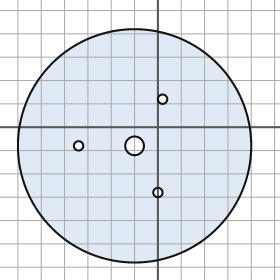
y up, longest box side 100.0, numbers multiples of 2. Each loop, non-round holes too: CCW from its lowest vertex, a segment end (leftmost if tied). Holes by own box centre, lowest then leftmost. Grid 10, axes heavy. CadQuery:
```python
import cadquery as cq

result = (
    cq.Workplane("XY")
    .moveTo(-10.0, -8.0)
    .circle(50.0)
    .moveTo(0.0, -28.0)
    .circle(2.0)
    .moveTo(-34.0, -8.0)
    .circle(2.0)
    .moveTo(-10.0, -8.0)
    .circle(4.0)
    .moveTo(2.0, 12.0)
    .circle(2.0)
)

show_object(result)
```